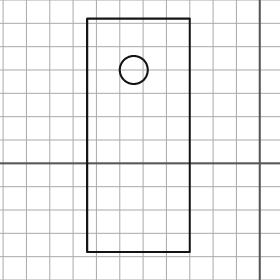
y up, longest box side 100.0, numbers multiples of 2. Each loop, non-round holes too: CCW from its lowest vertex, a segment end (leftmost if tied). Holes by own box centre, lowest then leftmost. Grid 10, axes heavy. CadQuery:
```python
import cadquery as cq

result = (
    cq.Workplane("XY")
    .moveTo(-74.0, -38.0)
    .lineTo(-30.0, -38.0)
    .lineTo(-30.0, 62.0)
    .lineTo(-74.0, 62.0)
    .close()
    .moveTo(-54.0, 40.0)
    .circle(6.0)
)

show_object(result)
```